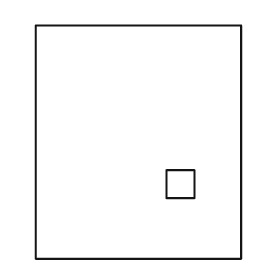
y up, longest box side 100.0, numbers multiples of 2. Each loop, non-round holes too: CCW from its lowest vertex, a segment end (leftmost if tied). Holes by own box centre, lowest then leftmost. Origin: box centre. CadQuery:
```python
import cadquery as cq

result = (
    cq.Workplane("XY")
    .moveTo(-44.0, -50.0)
    .lineTo(44.0, -50.0)
    .lineTo(44.0, 50.0)
    .lineTo(-44.0, 50.0)
    .close()
    .moveTo(12.0, -24.0)
    .lineTo(24.0, -24.0)
    .lineTo(24.0, -12.0)
    .lineTo(12.0, -12.0)
    .close()
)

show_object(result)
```